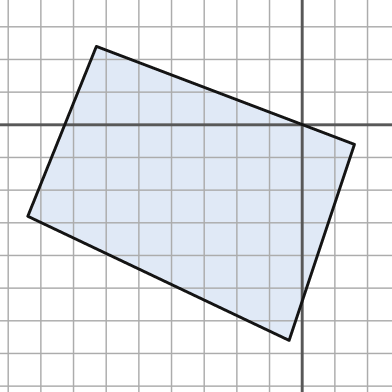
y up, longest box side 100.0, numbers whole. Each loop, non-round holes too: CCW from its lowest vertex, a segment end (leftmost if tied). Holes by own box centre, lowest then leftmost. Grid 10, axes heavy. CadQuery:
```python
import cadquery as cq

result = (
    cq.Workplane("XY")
    .moveTo(-4.0, -66.0)
    .lineTo(16.0, -6.0)
    .lineTo(-63.0, 24.0)
    .lineTo(-84.0, -28.0)
    .close()
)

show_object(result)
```